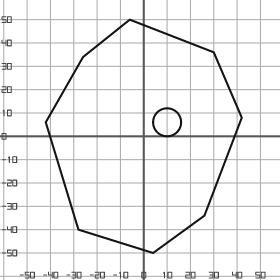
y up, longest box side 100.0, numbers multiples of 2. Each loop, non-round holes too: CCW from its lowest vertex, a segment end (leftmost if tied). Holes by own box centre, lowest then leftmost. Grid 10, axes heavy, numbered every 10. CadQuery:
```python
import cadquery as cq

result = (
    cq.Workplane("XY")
    .moveTo(4.0, -50.0)
    .lineTo(26.0, -34.0)
    .lineTo(42.0, 8.0)
    .lineTo(30.0, 36.0)
    .lineTo(-6.0, 50.0)
    .lineTo(-26.0, 34.0)
    .lineTo(-42.0, 6.0)
    .lineTo(-28.0, -40.0)
    .close()
    .moveTo(10.0, 6.0)
    .circle(6.0)
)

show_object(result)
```